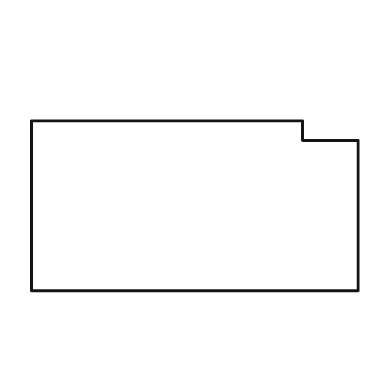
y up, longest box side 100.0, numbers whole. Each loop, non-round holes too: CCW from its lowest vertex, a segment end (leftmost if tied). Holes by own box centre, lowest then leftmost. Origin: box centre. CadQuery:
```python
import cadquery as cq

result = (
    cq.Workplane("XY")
    .moveTo(-50.0, -26.0)
    .lineTo(50.0, -26.0)
    .lineTo(50.0, 20.0)
    .lineTo(33.0, 20.0)
    .lineTo(33.0, 26.0)
    .lineTo(-50.0, 26.0)
    .close()
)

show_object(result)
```